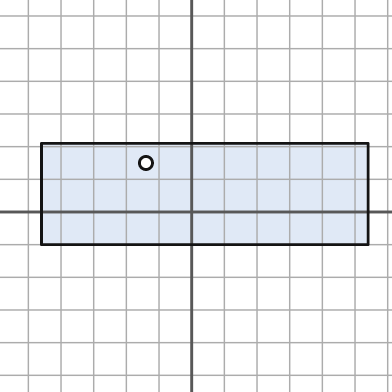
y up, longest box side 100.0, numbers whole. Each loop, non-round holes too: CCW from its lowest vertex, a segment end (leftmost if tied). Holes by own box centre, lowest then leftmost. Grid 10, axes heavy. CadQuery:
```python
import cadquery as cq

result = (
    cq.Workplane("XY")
    .moveTo(-46.0, -10.0)
    .lineTo(54.0, -10.0)
    .lineTo(54.0, 21.0)
    .lineTo(-46.0, 21.0)
    .close()
    .moveTo(-14.0, 15.0)
    .circle(2.0)
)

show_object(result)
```